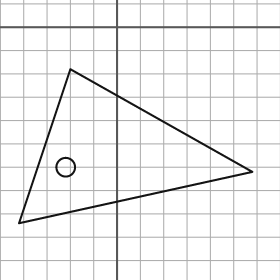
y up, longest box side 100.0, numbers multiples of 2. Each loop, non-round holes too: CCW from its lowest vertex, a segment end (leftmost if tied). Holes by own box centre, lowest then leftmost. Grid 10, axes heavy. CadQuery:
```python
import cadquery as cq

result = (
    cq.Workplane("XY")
    .moveTo(-42.0, -84.0)
    .lineTo(58.0, -62.0)
    .lineTo(-20.0, -18.0)
    .close()
    .moveTo(-22.0, -60.0)
    .circle(4.0)
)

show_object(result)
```